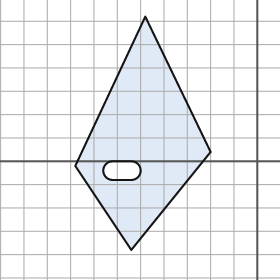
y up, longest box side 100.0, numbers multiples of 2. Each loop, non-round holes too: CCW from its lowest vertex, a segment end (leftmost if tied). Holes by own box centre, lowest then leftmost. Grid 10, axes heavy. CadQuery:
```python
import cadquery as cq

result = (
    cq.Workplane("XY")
    .moveTo(-54.0, -38.0)
    .lineTo(-20.0, 4.0)
    .lineTo(-48.0, 62.0)
    .lineTo(-78.0, -2.0)
    .close()
    .moveTo(-62.0, -8.0)
    .lineTo(-54.0, -8.0)
    .threePointArc((-50.0, -4.0), (-54.0, 0.0))
    .lineTo(-62.0, 0.0)
    .threePointArc((-66.0, -4.0), (-62.0, -8.0))
    .close()
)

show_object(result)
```